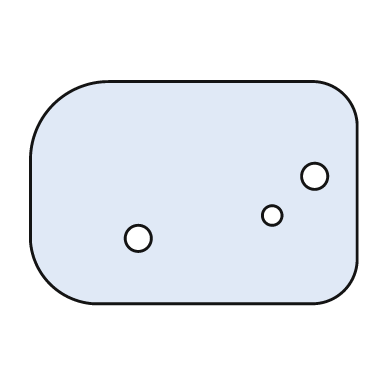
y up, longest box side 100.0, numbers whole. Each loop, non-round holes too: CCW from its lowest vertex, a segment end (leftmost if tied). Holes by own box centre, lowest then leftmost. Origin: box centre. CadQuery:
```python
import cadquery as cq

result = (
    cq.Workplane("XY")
    .moveTo(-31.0, -34.0)
    .lineTo(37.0, -34.0)
    .threePointArc((46.0, -30.0), (50.0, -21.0))
    .lineTo(50.0, 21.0)
    .threePointArc((46.0, 30.0), (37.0, 34.0))
    .lineTo(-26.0, 34.0)
    .threePointArc((-43.0, 27.0), (-50.0, 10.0))
    .lineTo(-50.0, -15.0)
    .threePointArc((-44.0, -28.0), (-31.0, -34.0))
    .close()
    .moveTo(-17.0, -14.0)
    .circle(4.0)
    .moveTo(24.0, -7.0)
    .circle(3.0)
    .moveTo(37.0, 5.0)
    .circle(4.0)
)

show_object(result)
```